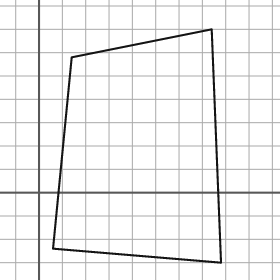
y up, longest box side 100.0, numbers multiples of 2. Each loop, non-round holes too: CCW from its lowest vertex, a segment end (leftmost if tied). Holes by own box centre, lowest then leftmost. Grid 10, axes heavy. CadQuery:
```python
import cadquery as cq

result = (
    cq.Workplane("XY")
    .moveTo(78.0, -30.0)
    .lineTo(74.0, 70.0)
    .lineTo(14.0, 58.0)
    .lineTo(6.0, -24.0)
    .close()
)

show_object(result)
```